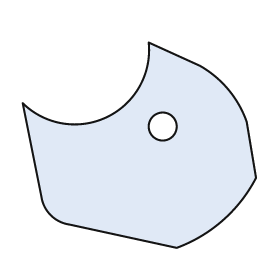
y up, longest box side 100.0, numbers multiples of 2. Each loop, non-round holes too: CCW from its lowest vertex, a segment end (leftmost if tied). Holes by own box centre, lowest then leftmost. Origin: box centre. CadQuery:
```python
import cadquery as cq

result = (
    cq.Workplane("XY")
    .moveTo(16.0, -44.0)
    .threePointArc((36.0, -32.0), (50.0, -14.0))
    .lineTo(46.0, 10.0)
    .threePointArc((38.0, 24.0), (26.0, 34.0))
    .lineTo(4.0, 44.0)
    .threePointArc((-14.0, 12.0), (-50.0, 18.0))
    .lineTo(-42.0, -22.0)
    .threePointArc((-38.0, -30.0), (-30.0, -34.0))
    .close()
    .moveTo(10.0, 8.0)
    .circle(6.0)
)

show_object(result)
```